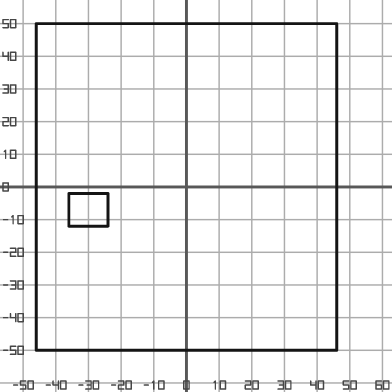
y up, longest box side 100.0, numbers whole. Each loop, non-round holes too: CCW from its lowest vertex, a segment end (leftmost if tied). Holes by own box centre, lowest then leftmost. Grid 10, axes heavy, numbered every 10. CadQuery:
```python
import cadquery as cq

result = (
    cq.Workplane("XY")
    .moveTo(-46.0, -50.0)
    .lineTo(46.0, -50.0)
    .lineTo(46.0, 50.0)
    .lineTo(-46.0, 50.0)
    .close()
    .moveTo(-36.0, -12.0)
    .lineTo(-24.0, -12.0)
    .lineTo(-24.0, -2.0)
    .lineTo(-36.0, -2.0)
    .close()
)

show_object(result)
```